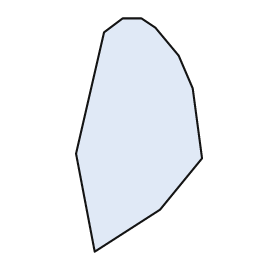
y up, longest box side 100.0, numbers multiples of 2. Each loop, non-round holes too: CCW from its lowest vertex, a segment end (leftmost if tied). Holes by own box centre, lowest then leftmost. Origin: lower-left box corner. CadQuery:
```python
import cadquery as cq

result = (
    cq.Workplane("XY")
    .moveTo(8.0, 0.0)
    .lineTo(36.0, 18.0)
    .lineTo(54.0, 40.0)
    .lineTo(50.0, 70.0)
    .lineTo(44.0, 84.0)
    .lineTo(34.0, 96.0)
    .lineTo(28.0, 100.0)
    .lineTo(20.0, 100.0)
    .lineTo(12.0, 94.0)
    .lineTo(0.0, 42.0)
    .close()
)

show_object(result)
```